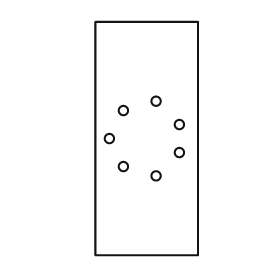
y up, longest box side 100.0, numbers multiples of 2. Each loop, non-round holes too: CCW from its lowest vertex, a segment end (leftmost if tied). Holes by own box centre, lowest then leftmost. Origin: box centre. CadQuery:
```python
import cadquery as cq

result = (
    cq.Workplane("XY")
    .moveTo(-22.0, -50.0)
    .lineTo(22.0, -50.0)
    .lineTo(22.0, 50.0)
    .lineTo(-22.0, 50.0)
    .close()
    .moveTo(4.0, -16.0)
    .circle(2.0)
    .moveTo(-10.0, -12.0)
    .circle(2.0)
    .moveTo(14.0, -6.0)
    .circle(2.0)
    .moveTo(-16.0, 0.0)
    .circle(2.0)
    .moveTo(14.0, 6.0)
    .circle(2.0)
    .moveTo(-10.0, 12.0)
    .circle(2.0)
    .moveTo(4.0, 16.0)
    .circle(2.0)
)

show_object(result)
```